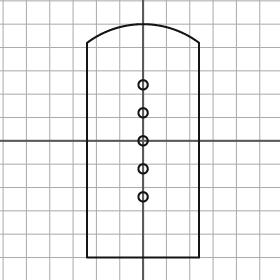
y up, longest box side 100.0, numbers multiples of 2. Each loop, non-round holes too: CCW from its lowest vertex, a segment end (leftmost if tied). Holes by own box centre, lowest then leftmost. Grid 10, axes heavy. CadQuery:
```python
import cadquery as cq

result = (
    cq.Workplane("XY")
    .moveTo(-24.0, -50.0)
    .lineTo(24.0, -50.0)
    .lineTo(24.0, 42.0)
    .threePointArc((0.0, 50.0), (-24.0, 42.0))
    .close()
    .moveTo(0.0, -24.0)
    .circle(2.0)
    .moveTo(0.0, -12.0)
    .circle(2.0)
    .moveTo(0.0, 0.0)
    .circle(2.0)
    .moveTo(0.0, 12.0)
    .circle(2.0)
    .moveTo(0.0, 24.0)
    .circle(2.0)
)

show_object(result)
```